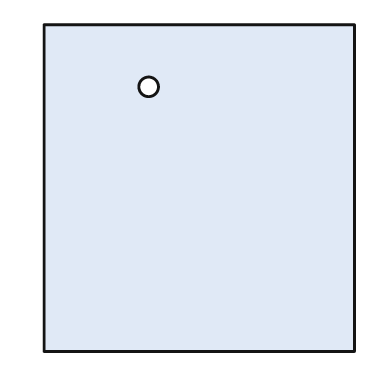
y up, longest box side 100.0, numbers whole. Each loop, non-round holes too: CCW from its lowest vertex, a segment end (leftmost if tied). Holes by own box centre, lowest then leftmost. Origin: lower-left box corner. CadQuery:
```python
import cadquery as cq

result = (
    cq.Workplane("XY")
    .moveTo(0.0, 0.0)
    .lineTo(95.0, 0.0)
    .lineTo(95.0, 100.0)
    .lineTo(0.0, 100.0)
    .close()
    .moveTo(32.0, 81.0)
    .circle(3.0)
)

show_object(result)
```